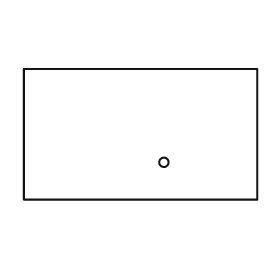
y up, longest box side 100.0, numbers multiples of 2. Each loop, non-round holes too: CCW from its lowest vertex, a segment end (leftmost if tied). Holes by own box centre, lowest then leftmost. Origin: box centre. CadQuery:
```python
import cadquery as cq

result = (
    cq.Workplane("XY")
    .moveTo(-50.0, -28.0)
    .lineTo(50.0, -28.0)
    .lineTo(50.0, 28.0)
    .lineTo(-50.0, 28.0)
    .close()
    .moveTo(10.0, -12.0)
    .circle(2.0)
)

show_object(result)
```